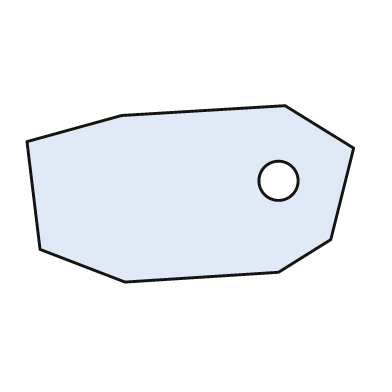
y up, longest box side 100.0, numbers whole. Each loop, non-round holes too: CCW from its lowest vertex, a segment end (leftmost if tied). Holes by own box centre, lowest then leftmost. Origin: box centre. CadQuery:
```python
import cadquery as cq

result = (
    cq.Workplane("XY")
    .moveTo(-20.0, -27.0)
    .lineTo(27.0, -24.0)
    .lineTo(43.0, -14.0)
    .lineTo(50.0, 14.0)
    .lineTo(29.0, 27.0)
    .lineTo(-21.0, 24.0)
    .lineTo(-50.0, 16.0)
    .lineTo(-46.0, -17.0)
    .close()
    .moveTo(27.0, 4.0)
    .circle(6.0)
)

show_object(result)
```